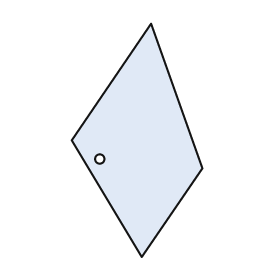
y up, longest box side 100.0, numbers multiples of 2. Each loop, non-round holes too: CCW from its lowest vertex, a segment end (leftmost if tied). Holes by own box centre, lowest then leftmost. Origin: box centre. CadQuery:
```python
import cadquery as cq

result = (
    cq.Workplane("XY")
    .moveTo(2.0, -50.0)
    .lineTo(28.0, -12.0)
    .lineTo(6.0, 50.0)
    .lineTo(-28.0, 0.0)
    .close()
    .moveTo(-16.0, -8.0)
    .circle(2.0)
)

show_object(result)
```